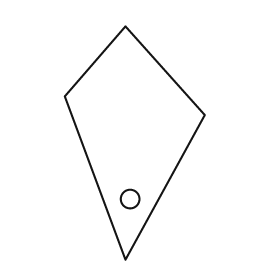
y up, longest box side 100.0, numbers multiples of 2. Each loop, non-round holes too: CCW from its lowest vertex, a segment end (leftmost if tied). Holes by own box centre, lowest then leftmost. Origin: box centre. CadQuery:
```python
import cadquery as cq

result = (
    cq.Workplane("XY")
    .moveTo(-4.0, -50.0)
    .lineTo(30.0, 12.0)
    .lineTo(-4.0, 50.0)
    .lineTo(-30.0, 20.0)
    .close()
    .moveTo(-2.0, -24.0)
    .circle(4.0)
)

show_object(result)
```